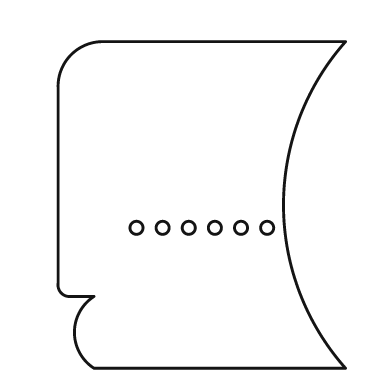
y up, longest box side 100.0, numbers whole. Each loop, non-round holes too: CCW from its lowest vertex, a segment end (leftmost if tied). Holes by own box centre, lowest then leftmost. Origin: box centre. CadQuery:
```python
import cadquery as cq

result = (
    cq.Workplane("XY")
    .moveTo(-33.0, -50.0)
    .lineTo(44.0, -50.0)
    .threePointArc((25.0, 0.0), (44.0, 50.0))
    .lineTo(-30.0, 50.0)
    .threePointArc((-40.0, 46.0), (-44.0, 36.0))
    .lineTo(-44.0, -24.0)
    .threePointArc((-43.0, -27.0), (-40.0, -28.0))
    .lineTo(-33.0, -28.0)
    .threePointArc((-39.0, -39.0), (-33.0, -50.0))
    .close()
    .moveTo(-20.0, -7.0)
    .circle(2.0)
    .moveTo(-12.0, -7.0)
    .circle(2.0)
    .moveTo(-4.0, -7.0)
    .circle(2.0)
    .moveTo(4.0, -7.0)
    .circle(2.0)
    .moveTo(12.0, -7.0)
    .circle(2.0)
    .moveTo(20.0, -7.0)
    .circle(2.0)
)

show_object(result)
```